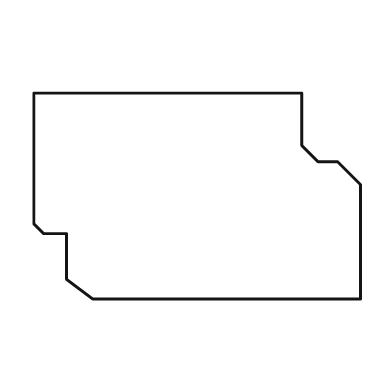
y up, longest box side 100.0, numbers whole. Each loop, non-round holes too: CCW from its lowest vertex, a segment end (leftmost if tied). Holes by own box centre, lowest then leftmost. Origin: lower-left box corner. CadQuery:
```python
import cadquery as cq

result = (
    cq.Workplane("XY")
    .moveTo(18.0, 0.0)
    .lineTo(100.0, 0.0)
    .lineTo(100.0, 35.0)
    .lineTo(93.0, 42.0)
    .lineTo(87.0, 42.0)
    .lineTo(82.0, 47.0)
    .lineTo(82.0, 63.0)
    .lineTo(0.0, 63.0)
    .lineTo(0.0, 23.0)
    .lineTo(3.0, 20.0)
    .lineTo(10.0, 20.0)
    .lineTo(10.0, 6.0)
    .close()
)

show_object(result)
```